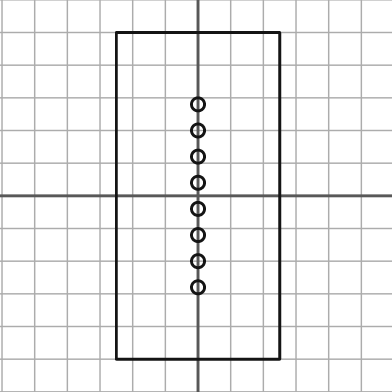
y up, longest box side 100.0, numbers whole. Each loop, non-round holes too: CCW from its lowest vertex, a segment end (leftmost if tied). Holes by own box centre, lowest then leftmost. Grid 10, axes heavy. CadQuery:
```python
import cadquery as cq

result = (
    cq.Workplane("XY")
    .moveTo(-25.0, -50.0)
    .lineTo(25.0, -50.0)
    .lineTo(25.0, 50.0)
    .lineTo(-25.0, 50.0)
    .close()
    .moveTo(0.0, -28.0)
    .circle(2.0)
    .moveTo(0.0, -20.0)
    .circle(2.0)
    .moveTo(0.0, -12.0)
    .circle(2.0)
    .moveTo(0.0, -4.0)
    .circle(2.0)
    .moveTo(0.0, 4.0)
    .circle(2.0)
    .moveTo(0.0, 12.0)
    .circle(2.0)
    .moveTo(0.0, 20.0)
    .circle(2.0)
    .moveTo(0.0, 28.0)
    .circle(2.0)
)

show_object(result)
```